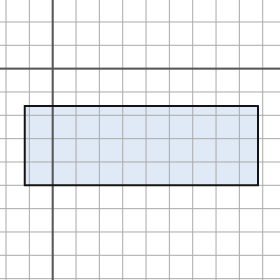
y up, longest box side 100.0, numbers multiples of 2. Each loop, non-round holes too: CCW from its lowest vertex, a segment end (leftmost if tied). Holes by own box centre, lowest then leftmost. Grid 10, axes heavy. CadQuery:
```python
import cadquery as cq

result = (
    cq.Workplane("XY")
    .moveTo(-12.0, -50.0)
    .lineTo(88.0, -50.0)
    .lineTo(88.0, -16.0)
    .lineTo(-12.0, -16.0)
    .close()
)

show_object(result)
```